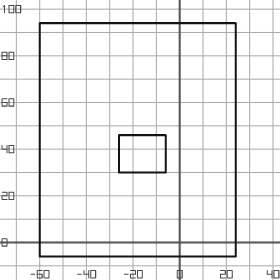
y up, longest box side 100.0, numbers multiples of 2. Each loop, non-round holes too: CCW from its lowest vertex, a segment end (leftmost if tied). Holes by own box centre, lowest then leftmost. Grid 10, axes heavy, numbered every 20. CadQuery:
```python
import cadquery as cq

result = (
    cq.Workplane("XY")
    .moveTo(-60.0, -6.0)
    .lineTo(24.0, -6.0)
    .lineTo(24.0, 94.0)
    .lineTo(-60.0, 94.0)
    .close()
    .moveTo(-26.0, 30.0)
    .lineTo(-6.0, 30.0)
    .lineTo(-6.0, 46.0)
    .lineTo(-26.0, 46.0)
    .close()
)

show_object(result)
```